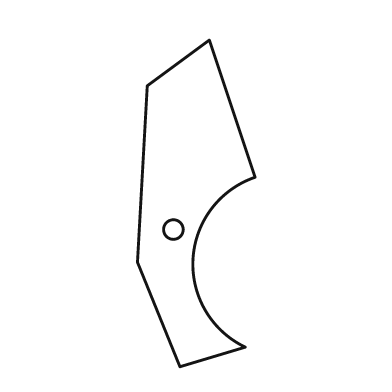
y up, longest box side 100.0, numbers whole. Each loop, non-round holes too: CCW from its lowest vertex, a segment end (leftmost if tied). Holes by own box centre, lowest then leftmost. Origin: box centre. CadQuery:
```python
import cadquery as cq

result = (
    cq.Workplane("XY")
    .moveTo(-5.0, -50.0)
    .lineTo(15.0, -44.0)
    .threePointArc((-1.0, -17.0), (18.0, 8.0))
    .lineTo(4.0, 50.0)
    .lineTo(-15.0, 36.0)
    .lineTo(-18.0, -18.0)
    .close()
    .moveTo(-7.0, -8.0)
    .circle(3.0)
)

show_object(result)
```